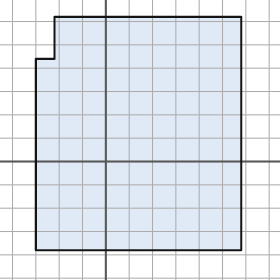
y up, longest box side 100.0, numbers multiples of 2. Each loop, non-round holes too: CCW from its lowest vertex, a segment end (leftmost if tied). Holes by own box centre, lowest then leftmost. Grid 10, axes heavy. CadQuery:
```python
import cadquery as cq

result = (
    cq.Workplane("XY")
    .moveTo(-30.0, -38.0)
    .lineTo(58.0, -38.0)
    .lineTo(58.0, 62.0)
    .lineTo(-22.0, 62.0)
    .lineTo(-22.0, 44.0)
    .lineTo(-30.0, 44.0)
    .close()
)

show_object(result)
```